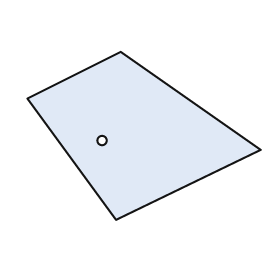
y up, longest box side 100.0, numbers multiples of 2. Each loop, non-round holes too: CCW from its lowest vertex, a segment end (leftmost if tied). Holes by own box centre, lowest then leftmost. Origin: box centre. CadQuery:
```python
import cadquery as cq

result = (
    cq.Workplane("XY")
    .moveTo(-12.0, -36.0)
    .lineTo(50.0, -6.0)
    .lineTo(-10.0, 36.0)
    .lineTo(-50.0, 16.0)
    .close()
    .moveTo(-18.0, -2.0)
    .circle(2.0)
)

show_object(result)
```